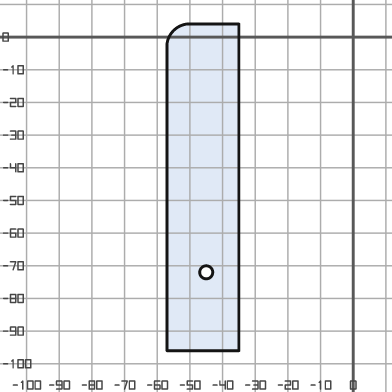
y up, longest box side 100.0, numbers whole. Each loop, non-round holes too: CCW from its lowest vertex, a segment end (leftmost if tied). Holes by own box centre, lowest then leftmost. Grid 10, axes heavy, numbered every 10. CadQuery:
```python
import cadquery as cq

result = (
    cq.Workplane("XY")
    .moveTo(-57.0, -96.0)
    .lineTo(-35.0, -96.0)
    .lineTo(-35.0, 4.0)
    .lineTo(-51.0, 4.0)
    .threePointArc((-55.0, 2.0), (-57.0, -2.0))
    .close()
    .moveTo(-45.0, -72.0)
    .circle(2.0)
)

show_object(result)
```